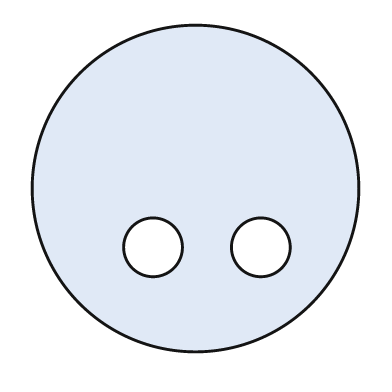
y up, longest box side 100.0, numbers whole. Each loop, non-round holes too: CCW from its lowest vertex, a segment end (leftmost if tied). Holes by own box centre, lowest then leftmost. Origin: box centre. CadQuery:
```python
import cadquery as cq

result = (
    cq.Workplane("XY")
    .moveTo(0.0, 0.0)
    .circle(50.0)
    .moveTo(-13.0, -18.0)
    .circle(9.0)
    .moveTo(20.0, -18.0)
    .circle(9.0)
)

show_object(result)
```